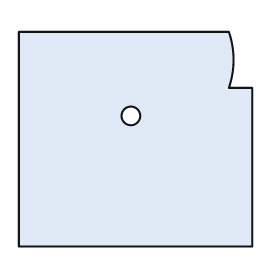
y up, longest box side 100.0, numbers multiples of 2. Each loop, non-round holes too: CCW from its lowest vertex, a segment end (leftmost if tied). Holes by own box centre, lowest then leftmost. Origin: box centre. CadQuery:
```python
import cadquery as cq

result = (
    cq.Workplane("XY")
    .moveTo(-50.0, -46.0)
    .lineTo(50.0, -46.0)
    .lineTo(50.0, 22.0)
    .lineTo(40.0, 22.0)
    .threePointArc((42.0, 34.0), (40.0, 46.0))
    .lineTo(-50.0, 46.0)
    .close()
    .moveTo(-2.0, 10.0)
    .circle(4.0)
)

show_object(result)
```